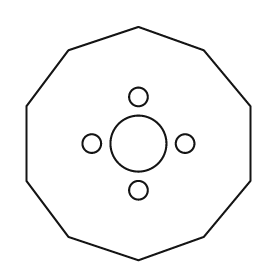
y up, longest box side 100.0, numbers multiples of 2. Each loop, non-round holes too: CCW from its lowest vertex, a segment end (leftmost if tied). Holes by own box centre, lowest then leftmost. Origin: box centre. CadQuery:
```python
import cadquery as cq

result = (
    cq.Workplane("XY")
    .moveTo(0.0, -50.0)
    .lineTo(28.0, -40.0)
    .lineTo(48.0, -16.0)
    .lineTo(48.0, 16.0)
    .lineTo(28.0, 40.0)
    .lineTo(0.0, 50.0)
    .lineTo(-30.0, 40.0)
    .lineTo(-48.0, 16.0)
    .lineTo(-48.0, -16.0)
    .lineTo(-30.0, -40.0)
    .close()
    .moveTo(0.0, -20.0)
    .circle(4.0)
    .moveTo(-20.0, 0.0)
    .circle(4.0)
    .moveTo(0.0, 0.0)
    .circle(12.0)
    .moveTo(20.0, 0.0)
    .circle(4.0)
    .moveTo(0.0, 20.0)
    .circle(4.0)
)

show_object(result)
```